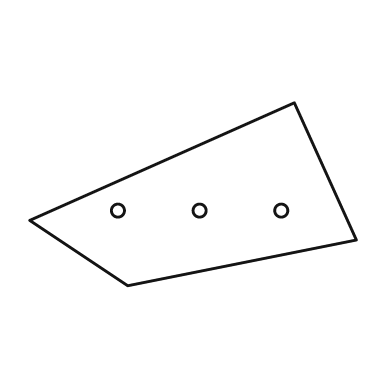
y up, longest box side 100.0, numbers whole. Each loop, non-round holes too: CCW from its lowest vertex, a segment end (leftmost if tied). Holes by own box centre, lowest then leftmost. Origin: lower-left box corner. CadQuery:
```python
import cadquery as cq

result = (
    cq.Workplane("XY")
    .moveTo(30.0, 0.0)
    .lineTo(100.0, 14.0)
    .lineTo(81.0, 56.0)
    .lineTo(0.0, 20.0)
    .close()
    .moveTo(27.0, 23.0)
    .circle(2.0)
    .moveTo(52.0, 23.0)
    .circle(2.0)
    .moveTo(77.0, 23.0)
    .circle(2.0)
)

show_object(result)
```